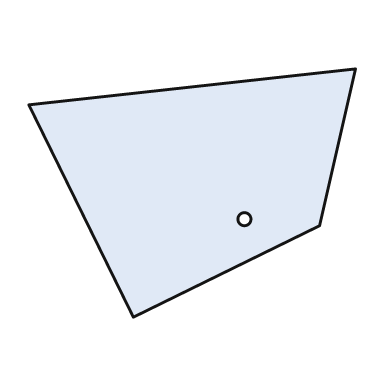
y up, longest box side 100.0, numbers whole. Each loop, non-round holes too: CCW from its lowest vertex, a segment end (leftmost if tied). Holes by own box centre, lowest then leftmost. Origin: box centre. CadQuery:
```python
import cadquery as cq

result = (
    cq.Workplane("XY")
    .moveTo(-18.0, -38.0)
    .lineTo(39.0, -10.0)
    .lineTo(50.0, 38.0)
    .lineTo(-50.0, 27.0)
    .close()
    .moveTo(16.0, -8.0)
    .circle(2.0)
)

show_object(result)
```